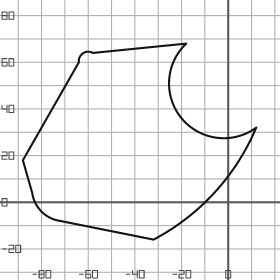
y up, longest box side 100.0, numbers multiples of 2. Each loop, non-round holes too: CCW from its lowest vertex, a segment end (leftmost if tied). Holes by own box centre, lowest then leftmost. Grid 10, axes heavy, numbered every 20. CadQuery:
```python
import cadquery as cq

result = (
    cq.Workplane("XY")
    .moveTo(-32.0, -16.0)
    .threePointArc((-6.0, 4.0), (12.0, 32.0))
    .threePointArc((-20.0, 36.0), (-18.0, 68.0))
    .lineTo(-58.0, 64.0)
    .threePointArc((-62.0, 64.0), (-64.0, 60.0))
    .lineTo(-88.0, 18.0)
    .lineTo(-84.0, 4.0)
    .threePointArc((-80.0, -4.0), (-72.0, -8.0))
    .close()
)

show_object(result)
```